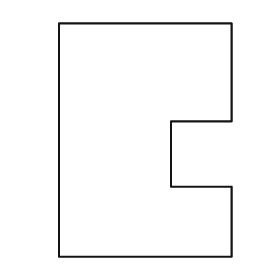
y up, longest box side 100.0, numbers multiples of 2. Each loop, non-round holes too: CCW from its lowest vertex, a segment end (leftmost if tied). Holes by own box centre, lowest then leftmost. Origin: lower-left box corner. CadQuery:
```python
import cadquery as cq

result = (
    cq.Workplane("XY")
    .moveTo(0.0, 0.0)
    .lineTo(74.0, 0.0)
    .lineTo(74.0, 30.0)
    .lineTo(48.0, 30.0)
    .lineTo(48.0, 58.0)
    .lineTo(74.0, 58.0)
    .lineTo(74.0, 100.0)
    .lineTo(0.0, 100.0)
    .close()
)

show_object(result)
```